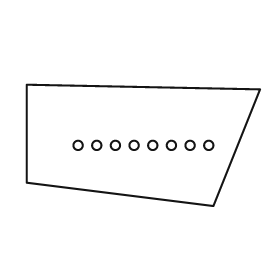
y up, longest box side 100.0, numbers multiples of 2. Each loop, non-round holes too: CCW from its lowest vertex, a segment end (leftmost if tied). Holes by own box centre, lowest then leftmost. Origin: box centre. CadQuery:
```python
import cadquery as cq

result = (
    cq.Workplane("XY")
    .moveTo(30.0, -26.0)
    .lineTo(50.0, 24.0)
    .lineTo(-50.0, 26.0)
    .lineTo(-50.0, -16.0)
    .close()
    .moveTo(-28.0, 0.0)
    .circle(2.0)
    .moveTo(-20.0, 0.0)
    .circle(2.0)
    .moveTo(-12.0, 0.0)
    .circle(2.0)
    .moveTo(-4.0, 0.0)
    .circle(2.0)
    .moveTo(4.0, 0.0)
    .circle(2.0)
    .moveTo(12.0, 0.0)
    .circle(2.0)
    .moveTo(20.0, 0.0)
    .circle(2.0)
    .moveTo(28.0, 0.0)
    .circle(2.0)
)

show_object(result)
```